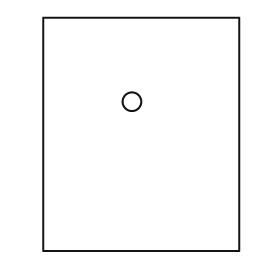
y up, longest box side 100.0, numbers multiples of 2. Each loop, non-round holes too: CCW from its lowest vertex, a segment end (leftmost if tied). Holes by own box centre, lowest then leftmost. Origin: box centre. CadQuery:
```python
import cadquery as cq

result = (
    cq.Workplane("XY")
    .moveTo(-42.0, -50.0)
    .lineTo(42.0, -50.0)
    .lineTo(42.0, 50.0)
    .lineTo(-42.0, 50.0)
    .close()
    .moveTo(-4.0, 14.0)
    .circle(4.0)
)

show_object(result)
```